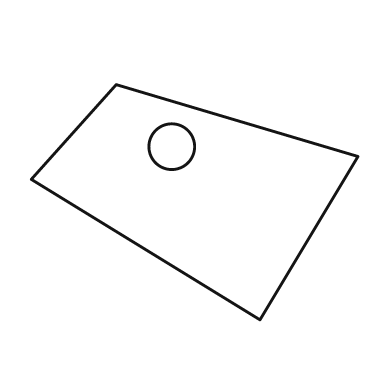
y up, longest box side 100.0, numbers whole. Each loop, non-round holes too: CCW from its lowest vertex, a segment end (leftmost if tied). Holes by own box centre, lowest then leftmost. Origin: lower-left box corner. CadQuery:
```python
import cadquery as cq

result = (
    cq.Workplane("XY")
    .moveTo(70.0, 0.0)
    .lineTo(100.0, 50.0)
    .lineTo(26.0, 72.0)
    .lineTo(0.0, 43.0)
    .close()
    .moveTo(43.0, 53.0)
    .circle(7.0)
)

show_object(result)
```